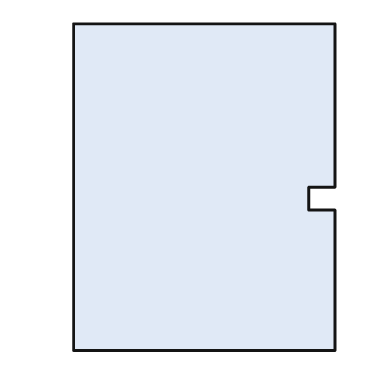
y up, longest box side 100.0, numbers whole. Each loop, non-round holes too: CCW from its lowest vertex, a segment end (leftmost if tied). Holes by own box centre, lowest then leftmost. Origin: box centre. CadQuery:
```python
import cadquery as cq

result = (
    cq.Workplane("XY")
    .moveTo(-40.0, -50.0)
    .lineTo(40.0, -50.0)
    .lineTo(40.0, -7.0)
    .lineTo(32.0, -7.0)
    .lineTo(32.0, 0.0)
    .lineTo(40.0, 0.0)
    .lineTo(40.0, 50.0)
    .lineTo(-40.0, 50.0)
    .close()
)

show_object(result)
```